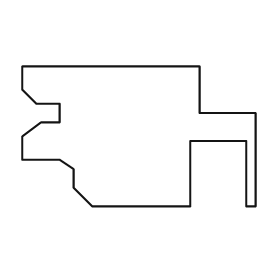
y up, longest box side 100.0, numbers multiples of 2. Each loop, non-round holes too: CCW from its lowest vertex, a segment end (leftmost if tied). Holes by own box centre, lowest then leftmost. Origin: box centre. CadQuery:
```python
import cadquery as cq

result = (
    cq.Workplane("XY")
    .moveTo(-20.0, -30.0)
    .lineTo(22.0, -30.0)
    .lineTo(22.0, -2.0)
    .lineTo(46.0, -2.0)
    .lineTo(46.0, -30.0)
    .lineTo(50.0, -30.0)
    .lineTo(50.0, 10.0)
    .lineTo(26.0, 10.0)
    .lineTo(26.0, 30.0)
    .lineTo(-50.0, 30.0)
    .lineTo(-50.0, 20.0)
    .lineTo(-44.0, 14.0)
    .lineTo(-34.0, 14.0)
    .lineTo(-34.0, 6.0)
    .lineTo(-42.0, 6.0)
    .lineTo(-50.0, 0.0)
    .lineTo(-50.0, -10.0)
    .lineTo(-34.0, -10.0)
    .lineTo(-28.0, -14.0)
    .lineTo(-28.0, -22.0)
    .close()
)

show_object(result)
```